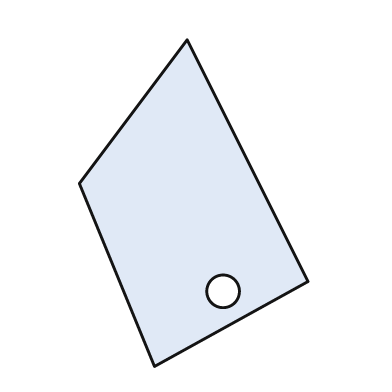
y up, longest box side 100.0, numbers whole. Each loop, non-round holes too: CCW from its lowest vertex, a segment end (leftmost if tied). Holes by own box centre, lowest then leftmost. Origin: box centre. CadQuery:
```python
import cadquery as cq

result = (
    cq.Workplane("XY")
    .moveTo(-12.0, -50.0)
    .lineTo(35.0, -24.0)
    .lineTo(-2.0, 50.0)
    .lineTo(-35.0, 6.0)
    .close()
    .moveTo(9.0, -27.0)
    .circle(5.0)
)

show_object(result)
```